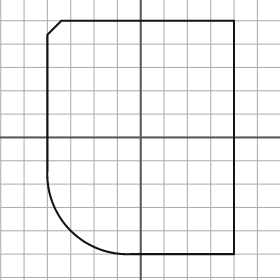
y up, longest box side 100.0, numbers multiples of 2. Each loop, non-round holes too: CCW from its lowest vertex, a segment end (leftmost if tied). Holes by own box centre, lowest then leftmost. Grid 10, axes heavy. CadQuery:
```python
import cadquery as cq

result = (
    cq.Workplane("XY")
    .moveTo(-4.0, -50.0)
    .lineTo(40.0, -50.0)
    .lineTo(40.0, 50.0)
    .lineTo(-34.0, 50.0)
    .lineTo(-40.0, 44.0)
    .lineTo(-40.0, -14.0)
    .threePointArc((-30.0, -40.0), (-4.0, -50.0))
    .close()
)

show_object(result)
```